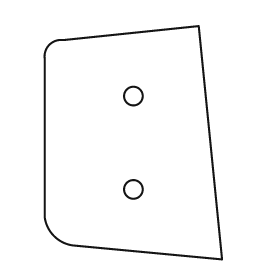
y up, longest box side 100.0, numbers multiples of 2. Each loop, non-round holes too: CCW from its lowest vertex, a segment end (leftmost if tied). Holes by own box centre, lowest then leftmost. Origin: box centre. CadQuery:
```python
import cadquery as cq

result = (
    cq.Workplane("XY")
    .moveTo(38.0, -50.0)
    .lineTo(28.0, 50.0)
    .lineTo(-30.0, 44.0)
    .threePointArc((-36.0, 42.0), (-38.0, 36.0))
    .lineTo(-38.0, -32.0)
    .threePointArc((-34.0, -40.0), (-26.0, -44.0))
    .close()
    .moveTo(0.0, -20.0)
    .circle(4.0)
    .moveTo(0.0, 20.0)
    .circle(4.0)
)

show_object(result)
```